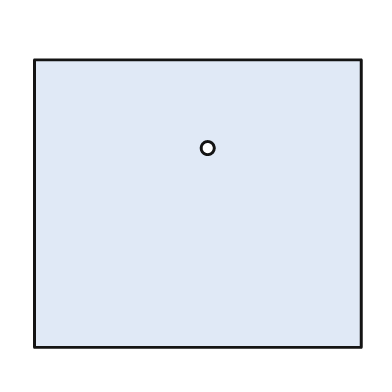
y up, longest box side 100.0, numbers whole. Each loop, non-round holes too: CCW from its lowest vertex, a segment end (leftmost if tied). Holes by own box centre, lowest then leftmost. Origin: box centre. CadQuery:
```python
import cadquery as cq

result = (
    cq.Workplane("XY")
    .moveTo(-50.0, -44.0)
    .lineTo(50.0, -44.0)
    .lineTo(50.0, 44.0)
    .lineTo(-50.0, 44.0)
    .close()
    .moveTo(3.0, 17.0)
    .circle(2.0)
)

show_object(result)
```